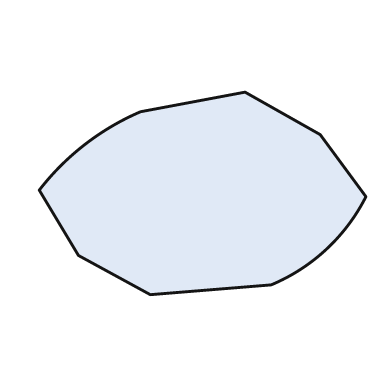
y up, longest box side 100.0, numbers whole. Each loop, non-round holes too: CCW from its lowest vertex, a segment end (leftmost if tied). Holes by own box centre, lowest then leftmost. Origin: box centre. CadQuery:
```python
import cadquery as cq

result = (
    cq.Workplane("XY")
    .moveTo(-16.0, -31.0)
    .lineTo(21.0, -28.0)
    .threePointArc((38.0, -17.0), (50.0, -1.0))
    .lineTo(36.0, 18.0)
    .lineTo(13.0, 31.0)
    .lineTo(-19.0, 25.0)
    .threePointArc((-36.0, 15.0), (-50.0, 1.0))
    .lineTo(-38.0, -19.0)
    .close()
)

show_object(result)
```